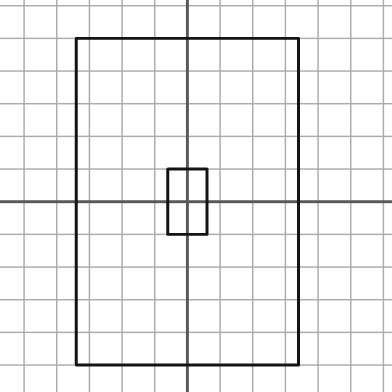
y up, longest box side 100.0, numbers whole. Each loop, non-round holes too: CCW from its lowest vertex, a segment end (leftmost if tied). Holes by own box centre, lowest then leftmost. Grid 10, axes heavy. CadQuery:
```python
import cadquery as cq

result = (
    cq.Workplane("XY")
    .moveTo(-34.0, -50.0)
    .lineTo(34.0, -50.0)
    .lineTo(34.0, 50.0)
    .lineTo(-34.0, 50.0)
    .close()
    .moveTo(-6.0, -10.0)
    .lineTo(6.0, -10.0)
    .lineTo(6.0, 10.0)
    .lineTo(-6.0, 10.0)
    .close()
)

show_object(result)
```